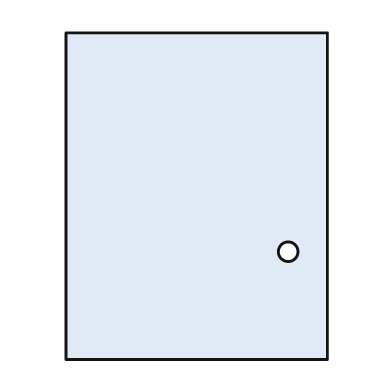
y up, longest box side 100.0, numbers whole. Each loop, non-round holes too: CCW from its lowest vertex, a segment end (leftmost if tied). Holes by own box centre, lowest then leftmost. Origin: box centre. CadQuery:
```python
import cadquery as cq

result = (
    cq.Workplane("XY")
    .moveTo(-40.0, -50.0)
    .lineTo(40.0, -50.0)
    .lineTo(40.0, 50.0)
    .lineTo(-40.0, 50.0)
    .close()
    .moveTo(28.0, -17.0)
    .circle(3.0)
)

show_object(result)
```